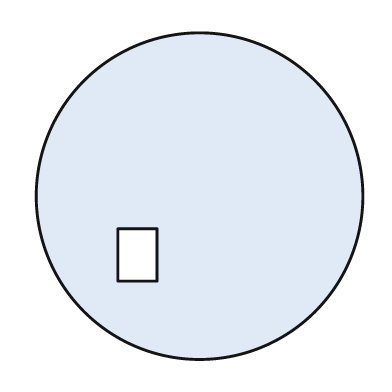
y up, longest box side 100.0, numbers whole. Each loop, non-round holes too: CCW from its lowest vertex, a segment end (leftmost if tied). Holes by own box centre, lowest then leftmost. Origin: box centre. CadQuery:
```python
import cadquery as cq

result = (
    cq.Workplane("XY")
    .moveTo(0.0, 0.0)
    .circle(50.0)
    .moveTo(-25.0, -26.0)
    .lineTo(-13.0, -26.0)
    .lineTo(-13.0, -10.0)
    .lineTo(-25.0, -10.0)
    .close()
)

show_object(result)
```